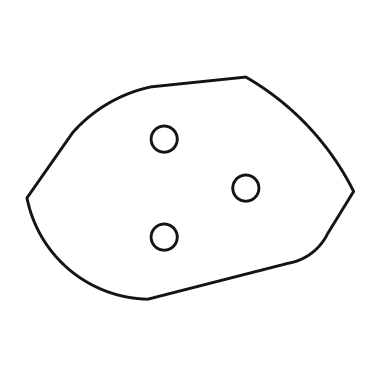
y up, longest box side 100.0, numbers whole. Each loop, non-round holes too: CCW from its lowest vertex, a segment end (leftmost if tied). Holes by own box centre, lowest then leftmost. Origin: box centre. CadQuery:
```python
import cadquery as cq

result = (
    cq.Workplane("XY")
    .moveTo(-13.0, -34.0)
    .lineTo(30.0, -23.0)
    .threePointArc((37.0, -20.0), (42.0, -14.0))
    .lineTo(50.0, -1.0)
    .threePointArc((36.0, 19.0), (17.0, 34.0))
    .lineTo(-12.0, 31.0)
    .threePointArc((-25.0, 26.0), (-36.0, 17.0))
    .lineTo(-50.0, -3.0)
    .threePointArc((-37.0, -25.0), (-13.0, -34.0))
    .close()
    .moveTo(-8.0, -15.0)
    .circle(4.0)
    .moveTo(17.0, 0.0)
    .circle(4.0)
    .moveTo(-8.0, 15.0)
    .circle(4.0)
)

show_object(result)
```